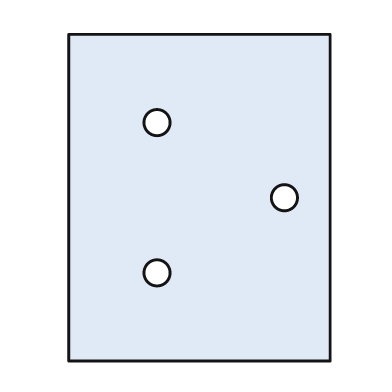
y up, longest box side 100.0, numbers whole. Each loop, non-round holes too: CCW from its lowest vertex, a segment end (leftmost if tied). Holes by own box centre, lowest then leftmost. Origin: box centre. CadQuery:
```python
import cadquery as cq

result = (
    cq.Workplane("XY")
    .moveTo(-40.0, -50.0)
    .lineTo(40.0, -50.0)
    .lineTo(40.0, 50.0)
    .lineTo(-40.0, 50.0)
    .close()
    .moveTo(-13.0, -23.0)
    .circle(4.0)
    .moveTo(26.0, 0.0)
    .circle(4.0)
    .moveTo(-13.0, 23.0)
    .circle(4.0)
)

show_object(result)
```